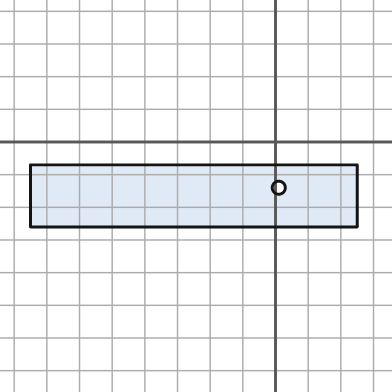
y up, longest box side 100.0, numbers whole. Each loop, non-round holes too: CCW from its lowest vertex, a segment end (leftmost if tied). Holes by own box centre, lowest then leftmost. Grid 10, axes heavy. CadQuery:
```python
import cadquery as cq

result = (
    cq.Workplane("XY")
    .moveTo(-75.0, -26.0)
    .lineTo(25.0, -26.0)
    .lineTo(25.0, -7.0)
    .lineTo(-75.0, -7.0)
    .close()
    .moveTo(1.0, -14.0)
    .circle(2.0)
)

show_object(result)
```